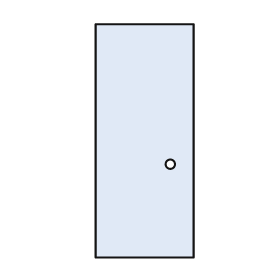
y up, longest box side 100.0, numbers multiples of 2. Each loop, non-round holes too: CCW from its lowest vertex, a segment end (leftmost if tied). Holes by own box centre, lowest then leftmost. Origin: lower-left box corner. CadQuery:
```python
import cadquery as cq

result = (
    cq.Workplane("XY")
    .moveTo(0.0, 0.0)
    .lineTo(42.0, 0.0)
    .lineTo(42.0, 100.0)
    .lineTo(0.0, 100.0)
    .close()
    .moveTo(32.0, 40.0)
    .circle(2.0)
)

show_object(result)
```